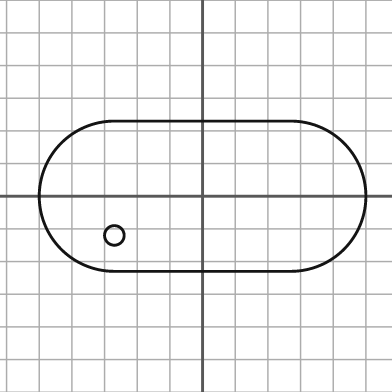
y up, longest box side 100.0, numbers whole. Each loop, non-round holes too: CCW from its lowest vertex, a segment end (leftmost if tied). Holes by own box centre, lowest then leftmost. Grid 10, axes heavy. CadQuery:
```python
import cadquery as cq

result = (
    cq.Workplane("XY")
    .moveTo(-27.0, -23.0)
    .lineTo(27.0, -23.0)
    .threePointArc((50.0, 0.0), (27.0, 23.0))
    .lineTo(-27.0, 23.0)
    .threePointArc((-50.0, 0.0), (-27.0, -23.0))
    .close()
    .moveTo(-27.0, -12.0)
    .circle(3.0)
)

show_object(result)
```